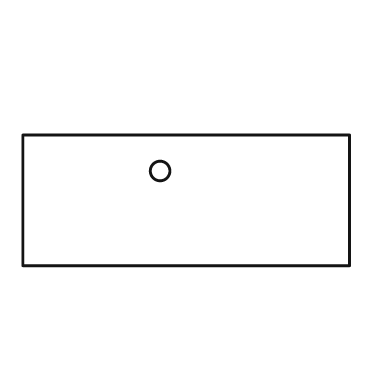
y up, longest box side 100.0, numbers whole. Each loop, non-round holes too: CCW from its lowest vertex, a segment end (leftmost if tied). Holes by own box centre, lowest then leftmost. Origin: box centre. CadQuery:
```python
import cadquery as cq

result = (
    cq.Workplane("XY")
    .moveTo(-50.0, -20.0)
    .lineTo(50.0, -20.0)
    .lineTo(50.0, 20.0)
    .lineTo(-50.0, 20.0)
    .close()
    .moveTo(-8.0, 9.0)
    .circle(3.0)
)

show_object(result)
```